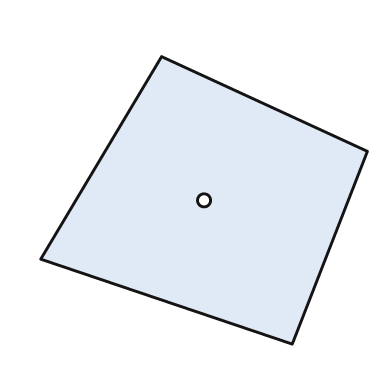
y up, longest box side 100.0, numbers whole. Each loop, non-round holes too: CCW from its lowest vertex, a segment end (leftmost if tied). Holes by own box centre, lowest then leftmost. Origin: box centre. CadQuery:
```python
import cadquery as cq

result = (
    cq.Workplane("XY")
    .moveTo(27.0, -44.0)
    .lineTo(50.0, 15.0)
    .lineTo(-13.0, 44.0)
    .lineTo(-50.0, -18.0)
    .close()
    .moveTo(0.0, 0.0)
    .circle(2.0)
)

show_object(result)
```